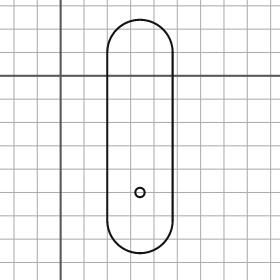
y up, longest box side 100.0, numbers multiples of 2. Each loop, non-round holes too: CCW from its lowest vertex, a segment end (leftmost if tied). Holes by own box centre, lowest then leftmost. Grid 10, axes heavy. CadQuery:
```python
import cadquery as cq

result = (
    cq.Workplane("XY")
    .moveTo(20.0, -62.0)
    .threePointArc((34.0, -76.0), (48.0, -62.0))
    .lineTo(48.0, 10.0)
    .threePointArc((34.0, 24.0), (20.0, 10.0))
    .close()
    .moveTo(34.0, -50.0)
    .circle(2.0)
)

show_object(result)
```